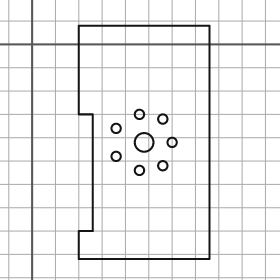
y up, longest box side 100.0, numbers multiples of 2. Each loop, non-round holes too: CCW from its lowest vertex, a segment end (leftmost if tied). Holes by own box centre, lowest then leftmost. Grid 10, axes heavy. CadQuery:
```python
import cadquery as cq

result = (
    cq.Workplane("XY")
    .moveTo(20.0, -92.0)
    .lineTo(76.0, -92.0)
    .lineTo(76.0, 8.0)
    .lineTo(20.0, 8.0)
    .lineTo(20.0, -30.0)
    .lineTo(26.0, -30.0)
    .lineTo(26.0, -80.0)
    .lineTo(20.0, -80.0)
    .close()
    .moveTo(46.0, -54.0)
    .circle(2.0)
    .moveTo(56.0, -52.0)
    .circle(2.0)
    .moveTo(36.0, -48.0)
    .circle(2.0)
    .moveTo(48.0, -42.0)
    .circle(4.0)
    .moveTo(60.0, -42.0)
    .circle(2.0)
    .moveTo(36.0, -36.0)
    .circle(2.0)
    .moveTo(56.0, -32.0)
    .circle(2.0)
    .moveTo(46.0, -30.0)
    .circle(2.0)
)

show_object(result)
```